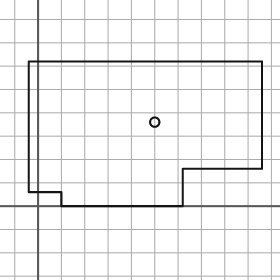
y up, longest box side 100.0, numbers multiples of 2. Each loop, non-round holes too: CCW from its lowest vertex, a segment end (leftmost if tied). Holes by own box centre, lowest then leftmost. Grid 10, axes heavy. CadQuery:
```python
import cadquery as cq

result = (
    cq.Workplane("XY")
    .moveTo(10.0, 0.0)
    .lineTo(62.0, 0.0)
    .lineTo(62.0, 16.0)
    .lineTo(96.0, 16.0)
    .lineTo(96.0, 62.0)
    .lineTo(-4.0, 62.0)
    .lineTo(-4.0, 6.0)
    .lineTo(10.0, 6.0)
    .close()
    .moveTo(50.0, 36.0)
    .circle(2.0)
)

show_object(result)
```